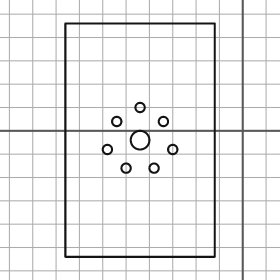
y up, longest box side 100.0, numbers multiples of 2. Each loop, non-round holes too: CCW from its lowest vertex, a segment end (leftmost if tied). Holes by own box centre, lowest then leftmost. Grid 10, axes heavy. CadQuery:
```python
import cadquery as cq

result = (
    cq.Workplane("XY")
    .moveTo(-76.0, -54.0)
    .lineTo(-12.0, -54.0)
    .lineTo(-12.0, 46.0)
    .lineTo(-76.0, 46.0)
    .close()
    .moveTo(-50.0, -16.0)
    .circle(2.0)
    .moveTo(-38.0, -16.0)
    .circle(2.0)
    .moveTo(-58.0, -8.0)
    .circle(2.0)
    .moveTo(-30.0, -8.0)
    .circle(2.0)
    .moveTo(-44.0, -4.0)
    .circle(4.0)
    .moveTo(-54.0, 4.0)
    .circle(2.0)
    .moveTo(-34.0, 4.0)
    .circle(2.0)
    .moveTo(-44.0, 10.0)
    .circle(2.0)
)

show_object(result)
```